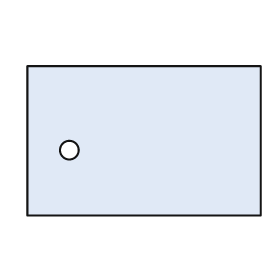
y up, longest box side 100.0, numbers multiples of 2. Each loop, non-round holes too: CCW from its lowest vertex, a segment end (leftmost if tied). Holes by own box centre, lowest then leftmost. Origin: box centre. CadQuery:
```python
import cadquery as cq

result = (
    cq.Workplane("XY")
    .moveTo(-50.0, -32.0)
    .lineTo(50.0, -32.0)
    .lineTo(50.0, 32.0)
    .lineTo(-50.0, 32.0)
    .close()
    .moveTo(-32.0, -4.0)
    .circle(4.0)
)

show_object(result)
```